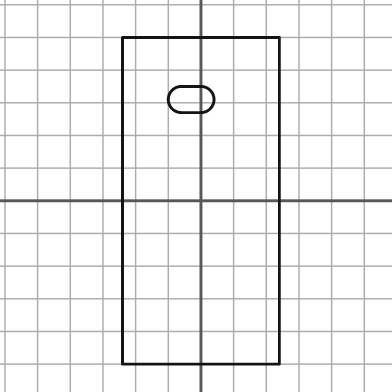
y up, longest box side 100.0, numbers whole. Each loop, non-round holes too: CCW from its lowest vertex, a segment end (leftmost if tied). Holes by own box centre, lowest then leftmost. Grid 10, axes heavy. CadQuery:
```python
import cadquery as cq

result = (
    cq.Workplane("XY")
    .moveTo(-24.0, -50.0)
    .lineTo(24.0, -50.0)
    .lineTo(24.0, 50.0)
    .lineTo(-24.0, 50.0)
    .close()
    .moveTo(-6.0, 27.0)
    .lineTo(0.0, 27.0)
    .threePointArc((4.0, 31.0), (0.0, 35.0))
    .lineTo(-6.0, 35.0)
    .threePointArc((-10.0, 31.0), (-6.0, 27.0))
    .close()
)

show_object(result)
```